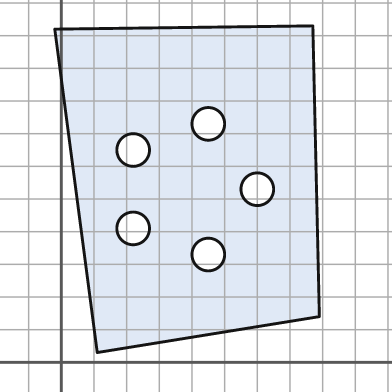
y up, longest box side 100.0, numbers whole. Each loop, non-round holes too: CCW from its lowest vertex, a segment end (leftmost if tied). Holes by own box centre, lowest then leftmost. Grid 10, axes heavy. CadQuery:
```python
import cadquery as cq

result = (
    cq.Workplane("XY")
    .moveTo(11.0, 3.0)
    .lineTo(79.0, 14.0)
    .lineTo(77.0, 103.0)
    .lineTo(-2.0, 102.0)
    .close()
    .moveTo(45.0, 33.0)
    .circle(5.0)
    .moveTo(22.0, 41.0)
    .circle(5.0)
    .moveTo(60.0, 53.0)
    .circle(5.0)
    .moveTo(22.0, 65.0)
    .circle(5.0)
    .moveTo(45.0, 73.0)
    .circle(5.0)
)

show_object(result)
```